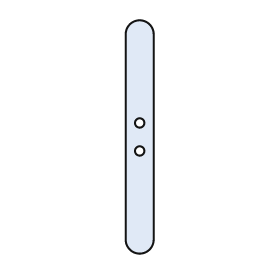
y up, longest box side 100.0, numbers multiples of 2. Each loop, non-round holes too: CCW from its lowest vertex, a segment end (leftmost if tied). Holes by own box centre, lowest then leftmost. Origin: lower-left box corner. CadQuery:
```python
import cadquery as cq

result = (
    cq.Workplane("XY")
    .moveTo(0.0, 6.0)
    .threePointArc((6.0, 0.0), (12.0, 6.0))
    .lineTo(12.0, 94.0)
    .threePointArc((6.0, 100.0), (0.0, 94.0))
    .close()
    .moveTo(6.0, 44.0)
    .circle(2.0)
    .moveTo(6.0, 56.0)
    .circle(2.0)
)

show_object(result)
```